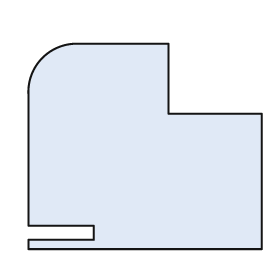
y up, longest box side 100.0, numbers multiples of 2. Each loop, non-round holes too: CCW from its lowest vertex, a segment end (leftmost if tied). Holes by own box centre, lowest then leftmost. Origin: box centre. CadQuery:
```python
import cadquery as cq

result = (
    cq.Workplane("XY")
    .moveTo(-50.0, -44.0)
    .lineTo(50.0, -44.0)
    .lineTo(50.0, 14.0)
    .lineTo(10.0, 14.0)
    .lineTo(10.0, 44.0)
    .lineTo(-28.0, 44.0)
    .threePointArc((-44.0, 38.0), (-50.0, 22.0))
    .lineTo(-50.0, -34.0)
    .lineTo(-22.0, -34.0)
    .lineTo(-22.0, -40.0)
    .lineTo(-50.0, -40.0)
    .close()
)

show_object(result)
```